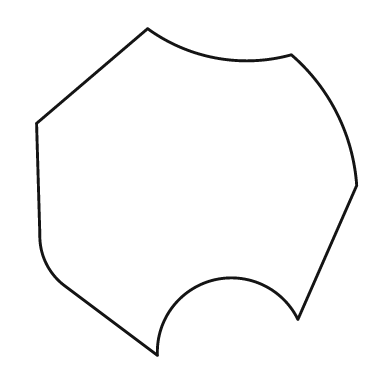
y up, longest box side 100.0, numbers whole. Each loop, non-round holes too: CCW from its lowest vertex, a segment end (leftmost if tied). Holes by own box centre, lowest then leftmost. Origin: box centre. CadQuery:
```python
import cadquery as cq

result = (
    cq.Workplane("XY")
    .moveTo(-12.0, -50.0)
    .threePointArc((5.0, -27.0), (31.0, -39.0))
    .lineTo(49.0, 2.0)
    .threePointArc((43.0, 24.0), (29.0, 42.0))
    .threePointArc((6.0, 41.0), (-15.0, 50.0))
    .lineTo(-49.0, 21.0)
    .lineTo(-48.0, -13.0)
    .threePointArc((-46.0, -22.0), (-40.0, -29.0))
    .close()
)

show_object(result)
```